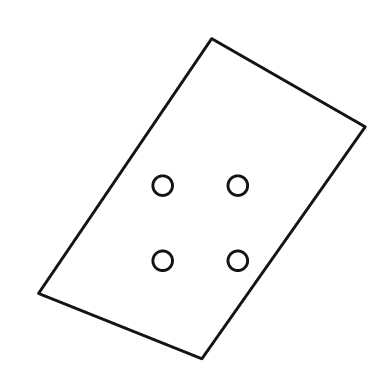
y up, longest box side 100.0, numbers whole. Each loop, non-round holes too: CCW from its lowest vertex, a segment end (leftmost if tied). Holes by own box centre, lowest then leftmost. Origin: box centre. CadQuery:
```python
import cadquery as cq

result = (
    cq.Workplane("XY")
    .moveTo(0.0, -49.0)
    .lineTo(50.0, 22.0)
    .lineTo(3.0, 49.0)
    .lineTo(-50.0, -29.0)
    .close()
    .moveTo(-12.0, -19.0)
    .circle(3.0)
    .moveTo(11.0, -19.0)
    .circle(3.0)
    .moveTo(-12.0, 4.0)
    .circle(3.0)
    .moveTo(11.0, 4.0)
    .circle(3.0)
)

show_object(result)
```